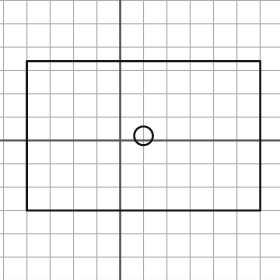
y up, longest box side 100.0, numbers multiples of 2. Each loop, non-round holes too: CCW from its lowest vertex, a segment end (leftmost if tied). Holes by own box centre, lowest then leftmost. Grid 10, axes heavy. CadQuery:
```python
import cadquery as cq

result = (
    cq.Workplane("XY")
    .moveTo(-40.0, -30.0)
    .lineTo(60.0, -30.0)
    .lineTo(60.0, 34.0)
    .lineTo(-40.0, 34.0)
    .close()
    .moveTo(10.0, 2.0)
    .circle(4.0)
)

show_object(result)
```